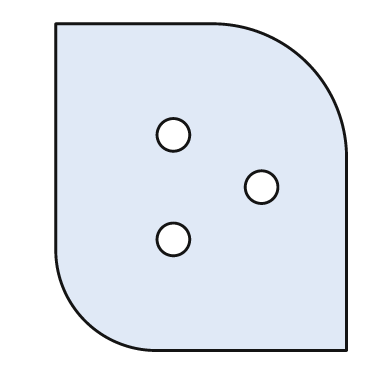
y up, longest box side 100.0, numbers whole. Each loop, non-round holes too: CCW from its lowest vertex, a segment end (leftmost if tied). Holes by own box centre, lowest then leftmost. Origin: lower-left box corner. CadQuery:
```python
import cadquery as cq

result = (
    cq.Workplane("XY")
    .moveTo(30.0, 0.0)
    .lineTo(89.0, 0.0)
    .lineTo(89.0, 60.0)
    .threePointArc((77.0, 88.0), (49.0, 100.0))
    .lineTo(0.0, 100.0)
    .lineTo(0.0, 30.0)
    .threePointArc((9.0, 9.0), (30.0, 0.0))
    .close()
    .moveTo(36.0, 34.0)
    .circle(5.0)
    .moveTo(63.0, 50.0)
    .circle(5.0)
    .moveTo(36.0, 66.0)
    .circle(5.0)
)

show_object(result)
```